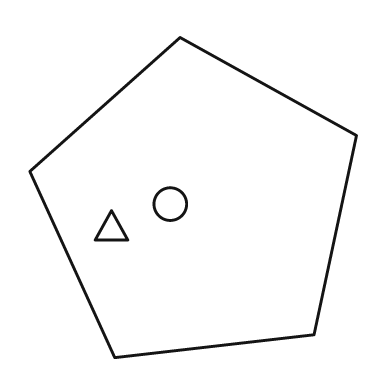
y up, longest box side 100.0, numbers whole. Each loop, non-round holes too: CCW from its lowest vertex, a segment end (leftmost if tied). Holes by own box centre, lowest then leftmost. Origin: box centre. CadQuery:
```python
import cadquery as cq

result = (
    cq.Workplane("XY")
    .moveTo(-24.0, -49.0)
    .lineTo(37.0, -42.0)
    .lineTo(50.0, 19.0)
    .lineTo(-4.0, 49.0)
    .lineTo(-50.0, 8.0)
    .close()
    .moveTo(-30.0, -13.0)
    .lineTo(-20.0, -13.0)
    .lineTo(-25.0, -4.0)
    .close()
    .moveTo(-7.0, -2.0)
    .circle(5.0)
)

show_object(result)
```